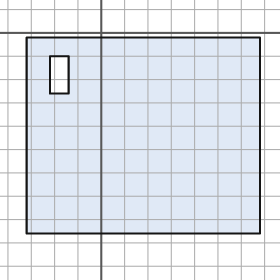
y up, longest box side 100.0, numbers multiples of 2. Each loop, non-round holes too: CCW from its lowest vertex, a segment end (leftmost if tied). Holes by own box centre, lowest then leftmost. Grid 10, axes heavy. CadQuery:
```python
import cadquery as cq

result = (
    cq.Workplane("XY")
    .moveTo(-32.0, -86.0)
    .lineTo(68.0, -86.0)
    .lineTo(68.0, -2.0)
    .lineTo(-32.0, -2.0)
    .close()
    .moveTo(-22.0, -26.0)
    .lineTo(-14.0, -26.0)
    .lineTo(-14.0, -10.0)
    .lineTo(-22.0, -10.0)
    .close()
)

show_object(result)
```